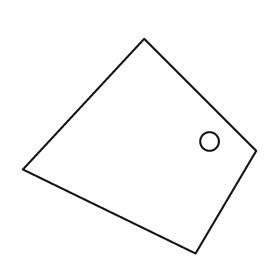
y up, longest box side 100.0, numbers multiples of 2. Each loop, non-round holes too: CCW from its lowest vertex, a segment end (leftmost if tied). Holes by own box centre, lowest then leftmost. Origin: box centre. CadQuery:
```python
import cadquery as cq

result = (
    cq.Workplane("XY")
    .moveTo(24.0, -46.0)
    .lineTo(50.0, -2.0)
    .lineTo(2.0, 46.0)
    .lineTo(-50.0, -10.0)
    .close()
    .moveTo(30.0, 2.0)
    .circle(4.0)
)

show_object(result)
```